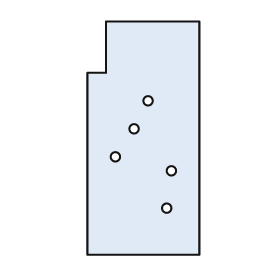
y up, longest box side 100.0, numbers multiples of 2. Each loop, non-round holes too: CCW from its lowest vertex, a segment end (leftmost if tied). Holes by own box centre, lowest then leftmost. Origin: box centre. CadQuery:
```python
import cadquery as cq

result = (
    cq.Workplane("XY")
    .moveTo(-24.0, -50.0)
    .lineTo(24.0, -50.0)
    .lineTo(24.0, 50.0)
    .lineTo(-16.0, 50.0)
    .lineTo(-16.0, 28.0)
    .lineTo(-24.0, 28.0)
    .close()
    .moveTo(10.0, -30.0)
    .circle(2.0)
    .moveTo(12.0, -14.0)
    .circle(2.0)
    .moveTo(-12.0, -8.0)
    .circle(2.0)
    .moveTo(-4.0, 4.0)
    .circle(2.0)
    .moveTo(2.0, 16.0)
    .circle(2.0)
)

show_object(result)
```